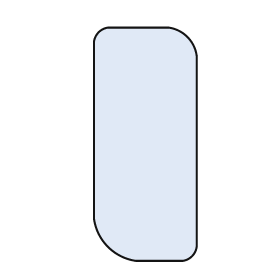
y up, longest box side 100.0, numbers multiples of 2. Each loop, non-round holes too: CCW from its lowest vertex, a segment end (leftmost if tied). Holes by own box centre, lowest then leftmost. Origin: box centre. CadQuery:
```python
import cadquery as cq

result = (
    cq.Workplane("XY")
    .moveTo(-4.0, -50.0)
    .lineTo(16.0, -50.0)
    .threePointArc((20.0, -48.0), (22.0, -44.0))
    .lineTo(22.0, 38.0)
    .threePointArc((18.0, 46.0), (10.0, 50.0))
    .lineTo(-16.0, 50.0)
    .threePointArc((-20.0, 48.0), (-22.0, 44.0))
    .lineTo(-22.0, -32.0)
    .threePointArc((-16.0, -44.0), (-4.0, -50.0))
    .close()
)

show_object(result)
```